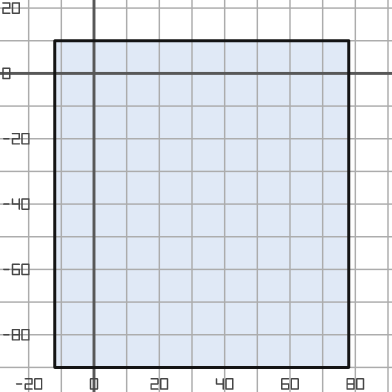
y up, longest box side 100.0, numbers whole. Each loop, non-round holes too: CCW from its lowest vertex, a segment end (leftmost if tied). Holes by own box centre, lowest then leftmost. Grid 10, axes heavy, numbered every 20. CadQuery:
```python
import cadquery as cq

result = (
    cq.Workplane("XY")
    .moveTo(-12.0, -90.0)
    .lineTo(78.0, -90.0)
    .lineTo(78.0, 10.0)
    .lineTo(-12.0, 10.0)
    .close()
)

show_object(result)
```